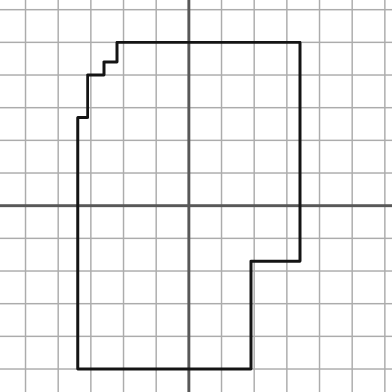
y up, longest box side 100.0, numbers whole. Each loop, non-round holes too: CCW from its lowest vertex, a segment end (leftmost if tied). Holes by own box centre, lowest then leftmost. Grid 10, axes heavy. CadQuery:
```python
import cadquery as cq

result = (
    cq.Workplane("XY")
    .moveTo(-34.0, -50.0)
    .lineTo(19.0, -50.0)
    .lineTo(19.0, -17.0)
    .lineTo(34.0, -17.0)
    .lineTo(34.0, 50.0)
    .lineTo(-22.0, 50.0)
    .lineTo(-22.0, 44.0)
    .lineTo(-26.0, 44.0)
    .lineTo(-26.0, 40.0)
    .lineTo(-31.0, 40.0)
    .lineTo(-31.0, 27.0)
    .lineTo(-34.0, 27.0)
    .close()
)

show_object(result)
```